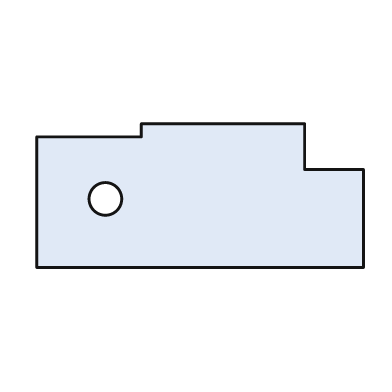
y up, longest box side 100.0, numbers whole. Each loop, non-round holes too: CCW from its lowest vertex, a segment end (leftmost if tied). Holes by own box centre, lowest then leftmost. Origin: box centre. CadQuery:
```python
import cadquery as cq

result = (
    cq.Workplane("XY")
    .moveTo(-50.0, -22.0)
    .lineTo(50.0, -22.0)
    .lineTo(50.0, 8.0)
    .lineTo(32.0, 8.0)
    .lineTo(32.0, 22.0)
    .lineTo(-18.0, 22.0)
    .lineTo(-18.0, 18.0)
    .lineTo(-50.0, 18.0)
    .close()
    .moveTo(-29.0, -1.0)
    .circle(5.0)
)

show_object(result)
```